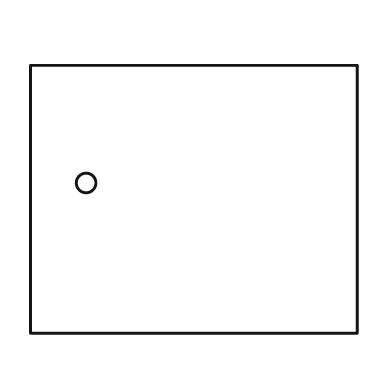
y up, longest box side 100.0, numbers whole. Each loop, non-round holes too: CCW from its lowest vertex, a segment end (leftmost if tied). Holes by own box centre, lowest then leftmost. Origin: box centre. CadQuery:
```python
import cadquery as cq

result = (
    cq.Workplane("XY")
    .moveTo(-50.0, -41.0)
    .lineTo(50.0, -41.0)
    .lineTo(50.0, 41.0)
    .lineTo(-50.0, 41.0)
    .close()
    .moveTo(-33.0, 5.0)
    .circle(3.0)
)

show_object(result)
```